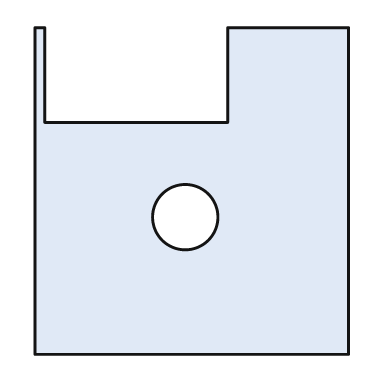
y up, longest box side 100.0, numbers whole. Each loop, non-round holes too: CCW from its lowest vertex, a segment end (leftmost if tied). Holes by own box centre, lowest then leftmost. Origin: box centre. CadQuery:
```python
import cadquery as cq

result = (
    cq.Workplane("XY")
    .moveTo(-48.0, -50.0)
    .lineTo(48.0, -50.0)
    .lineTo(48.0, 50.0)
    .lineTo(11.0, 50.0)
    .lineTo(11.0, 21.0)
    .lineTo(-45.0, 21.0)
    .lineTo(-45.0, 50.0)
    .lineTo(-48.0, 50.0)
    .close()
    .moveTo(-2.0, -8.0)
    .circle(10.0)
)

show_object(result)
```